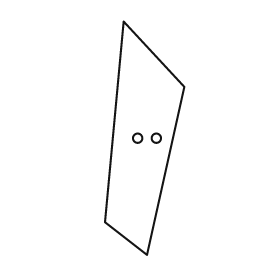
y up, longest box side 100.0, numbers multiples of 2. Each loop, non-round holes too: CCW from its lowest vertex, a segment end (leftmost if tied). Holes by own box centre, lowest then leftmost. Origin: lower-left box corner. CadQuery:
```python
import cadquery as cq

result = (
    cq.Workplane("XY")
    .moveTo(18.0, 0.0)
    .lineTo(34.0, 72.0)
    .lineTo(8.0, 100.0)
    .lineTo(0.0, 14.0)
    .close()
    .moveTo(14.0, 50.0)
    .circle(2.0)
    .moveTo(22.0, 50.0)
    .circle(2.0)
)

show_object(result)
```